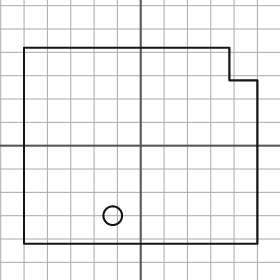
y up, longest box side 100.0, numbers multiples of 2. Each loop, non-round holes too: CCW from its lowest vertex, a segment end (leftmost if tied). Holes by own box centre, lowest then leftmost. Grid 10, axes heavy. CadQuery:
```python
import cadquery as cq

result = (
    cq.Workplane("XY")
    .moveTo(-50.0, -42.0)
    .lineTo(50.0, -42.0)
    .lineTo(50.0, 28.0)
    .lineTo(38.0, 28.0)
    .lineTo(38.0, 42.0)
    .lineTo(-50.0, 42.0)
    .close()
    .moveTo(-12.0, -30.0)
    .circle(4.0)
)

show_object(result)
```